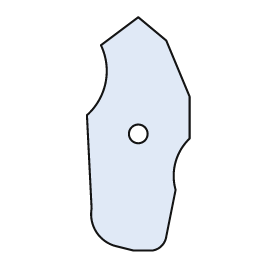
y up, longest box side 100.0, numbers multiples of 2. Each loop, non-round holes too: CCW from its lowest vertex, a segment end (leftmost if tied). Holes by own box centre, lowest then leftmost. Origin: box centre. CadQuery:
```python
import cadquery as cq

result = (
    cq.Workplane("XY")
    .moveTo(-2.0, -50.0)
    .lineTo(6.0, -50.0)
    .threePointArc((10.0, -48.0), (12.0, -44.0))
    .lineTo(16.0, -24.0)
    .threePointArc((16.0, -12.0), (22.0, -2.0))
    .lineTo(22.0, 16.0)
    .lineTo(12.0, 40.0)
    .lineTo(0.0, 50.0)
    .lineTo(-16.0, 38.0)
    .threePointArc((-14.0, 22.0), (-22.0, 8.0))
    .lineTo(-20.0, -32.0)
    .threePointArc((-18.0, -42.0), (-10.0, -48.0))
    .close()
    .moveTo(0.0, 0.0)
    .circle(4.0)
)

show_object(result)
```